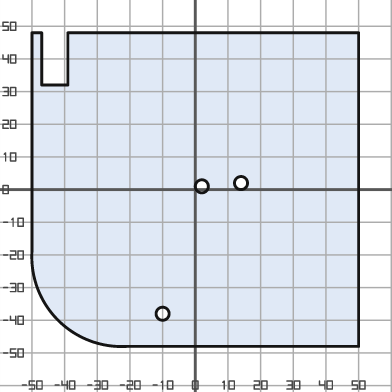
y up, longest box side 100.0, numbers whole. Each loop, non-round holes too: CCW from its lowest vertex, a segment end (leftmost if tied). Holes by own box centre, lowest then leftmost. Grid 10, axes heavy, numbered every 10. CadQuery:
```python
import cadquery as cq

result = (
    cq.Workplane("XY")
    .moveTo(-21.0, -48.0)
    .lineTo(50.0, -48.0)
    .lineTo(50.0, 48.0)
    .lineTo(-39.0, 48.0)
    .lineTo(-39.0, 32.0)
    .lineTo(-47.0, 32.0)
    .lineTo(-47.0, 48.0)
    .lineTo(-50.0, 48.0)
    .lineTo(-50.0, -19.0)
    .threePointArc((-42.0, -40.0), (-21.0, -48.0))
    .close()
    .moveTo(-10.0, -38.0)
    .circle(2.0)
    .moveTo(2.0, 1.0)
    .circle(2.0)
    .moveTo(14.0, 2.0)
    .circle(2.0)
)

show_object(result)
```